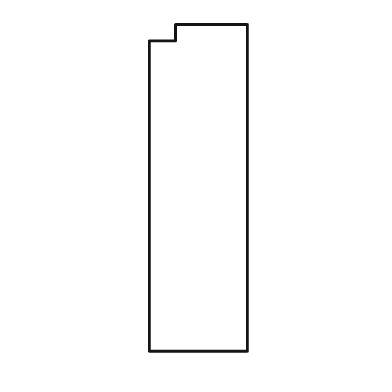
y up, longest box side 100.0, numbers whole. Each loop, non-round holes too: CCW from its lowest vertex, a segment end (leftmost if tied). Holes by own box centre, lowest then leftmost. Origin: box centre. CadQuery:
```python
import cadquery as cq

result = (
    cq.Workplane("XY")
    .moveTo(-15.0, -50.0)
    .lineTo(15.0, -50.0)
    .lineTo(15.0, 50.0)
    .lineTo(-7.0, 50.0)
    .lineTo(-7.0, 45.0)
    .lineTo(-15.0, 45.0)
    .close()
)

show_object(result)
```